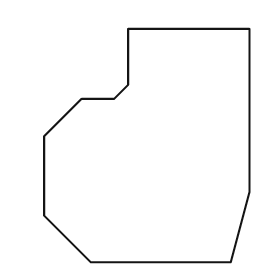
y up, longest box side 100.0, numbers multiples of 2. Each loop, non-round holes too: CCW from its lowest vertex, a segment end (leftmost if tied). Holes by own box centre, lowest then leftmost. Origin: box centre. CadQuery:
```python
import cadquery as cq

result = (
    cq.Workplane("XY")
    .moveTo(-24.0, -50.0)
    .lineTo(36.0, -50.0)
    .lineTo(44.0, -20.0)
    .lineTo(44.0, 50.0)
    .lineTo(-8.0, 50.0)
    .lineTo(-8.0, 26.0)
    .lineTo(-14.0, 20.0)
    .lineTo(-28.0, 20.0)
    .lineTo(-44.0, 4.0)
    .lineTo(-44.0, -30.0)
    .close()
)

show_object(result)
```